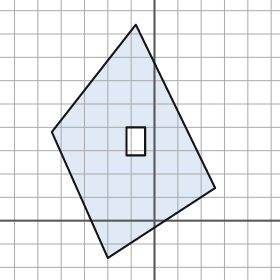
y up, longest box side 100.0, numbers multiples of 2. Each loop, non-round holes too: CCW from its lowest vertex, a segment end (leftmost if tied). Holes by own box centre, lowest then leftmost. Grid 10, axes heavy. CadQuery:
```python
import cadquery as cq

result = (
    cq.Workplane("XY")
    .moveTo(-20.0, -16.0)
    .lineTo(26.0, 14.0)
    .lineTo(-8.0, 84.0)
    .lineTo(-44.0, 38.0)
    .close()
    .moveTo(-12.0, 28.0)
    .lineTo(-4.0, 28.0)
    .lineTo(-4.0, 40.0)
    .lineTo(-12.0, 40.0)
    .close()
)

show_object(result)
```